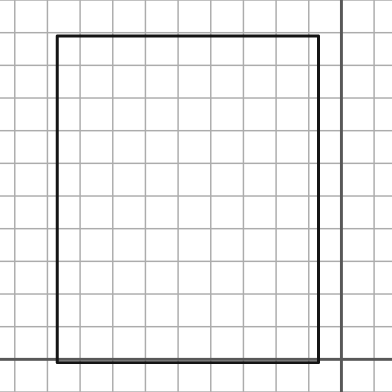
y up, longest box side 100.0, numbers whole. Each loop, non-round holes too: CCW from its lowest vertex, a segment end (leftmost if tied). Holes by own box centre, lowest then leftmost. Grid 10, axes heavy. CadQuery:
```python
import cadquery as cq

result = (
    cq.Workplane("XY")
    .moveTo(-87.0, -1.0)
    .lineTo(-7.0, -1.0)
    .lineTo(-7.0, 99.0)
    .lineTo(-87.0, 99.0)
    .close()
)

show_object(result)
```